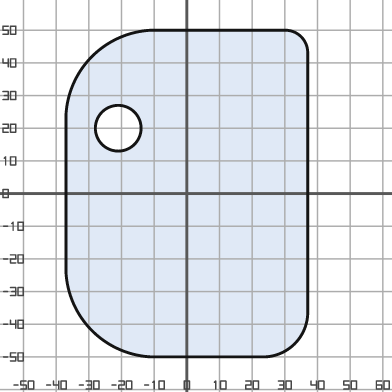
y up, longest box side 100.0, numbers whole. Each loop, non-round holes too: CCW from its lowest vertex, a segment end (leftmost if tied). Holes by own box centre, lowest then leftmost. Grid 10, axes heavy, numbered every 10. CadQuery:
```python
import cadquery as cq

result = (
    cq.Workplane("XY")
    .moveTo(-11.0, -50.0)
    .lineTo(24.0, -50.0)
    .threePointArc((33.0, -46.0), (37.0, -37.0))
    .lineTo(37.0, 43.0)
    .threePointArc((35.0, 48.0), (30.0, 50.0))
    .lineTo(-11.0, 50.0)
    .threePointArc((-29.0, 42.0), (-37.0, 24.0))
    .lineTo(-37.0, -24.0)
    .threePointArc((-29.0, -42.0), (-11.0, -50.0))
    .close()
    .moveTo(-21.0, 20.0)
    .circle(7.0)
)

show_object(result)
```